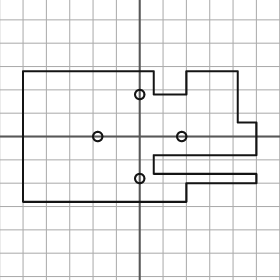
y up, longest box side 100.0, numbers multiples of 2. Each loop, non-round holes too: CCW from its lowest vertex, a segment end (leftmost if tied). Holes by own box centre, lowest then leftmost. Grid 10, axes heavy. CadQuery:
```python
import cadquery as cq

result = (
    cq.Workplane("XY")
    .moveTo(-50.0, -28.0)
    .lineTo(20.0, -28.0)
    .lineTo(20.0, -20.0)
    .lineTo(50.0, -20.0)
    .lineTo(50.0, -16.0)
    .lineTo(6.0, -16.0)
    .lineTo(6.0, -8.0)
    .lineTo(50.0, -8.0)
    .lineTo(50.0, 6.0)
    .lineTo(42.0, 6.0)
    .lineTo(42.0, 28.0)
    .lineTo(20.0, 28.0)
    .lineTo(20.0, 18.0)
    .lineTo(6.0, 18.0)
    .lineTo(6.0, 28.0)
    .lineTo(-50.0, 28.0)
    .close()
    .moveTo(0.0, -18.0)
    .circle(2.0)
    .moveTo(-18.0, 0.0)
    .circle(2.0)
    .moveTo(18.0, 0.0)
    .circle(2.0)
    .moveTo(0.0, 18.0)
    .circle(2.0)
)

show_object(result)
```